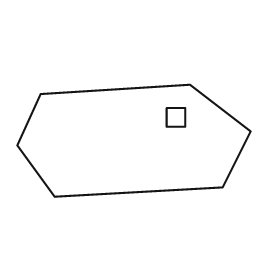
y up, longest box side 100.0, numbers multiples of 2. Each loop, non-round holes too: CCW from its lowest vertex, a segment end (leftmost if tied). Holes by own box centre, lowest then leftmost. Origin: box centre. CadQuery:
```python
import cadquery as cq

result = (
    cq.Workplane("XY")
    .moveTo(-34.0, -24.0)
    .lineTo(38.0, -20.0)
    .lineTo(50.0, 4.0)
    .lineTo(24.0, 24.0)
    .lineTo(-40.0, 20.0)
    .lineTo(-50.0, -2.0)
    .close()
    .moveTo(14.0, 6.0)
    .lineTo(22.0, 6.0)
    .lineTo(22.0, 14.0)
    .lineTo(14.0, 14.0)
    .close()
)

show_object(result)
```